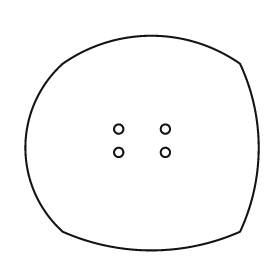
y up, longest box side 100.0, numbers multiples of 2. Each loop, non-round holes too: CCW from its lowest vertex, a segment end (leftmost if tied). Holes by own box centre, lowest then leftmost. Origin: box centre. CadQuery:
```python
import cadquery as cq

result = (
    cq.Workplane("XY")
    .moveTo(-34.0, -38.0)
    .threePointArc((4.0, -46.0), (42.0, -38.0))
    .threePointArc((50.0, -2.0), (42.0, 34.0))
    .threePointArc((4.0, 46.0), (-34.0, 34.0))
    .threePointArc((-50.0, -2.0), (-34.0, -38.0))
    .close()
    .moveTo(-10.0, -4.0)
    .circle(2.0)
    .moveTo(10.0, -4.0)
    .circle(2.0)
    .moveTo(-10.0, 6.0)
    .circle(2.0)
    .moveTo(10.0, 6.0)
    .circle(2.0)
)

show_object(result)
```